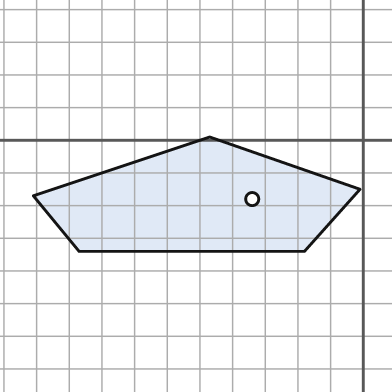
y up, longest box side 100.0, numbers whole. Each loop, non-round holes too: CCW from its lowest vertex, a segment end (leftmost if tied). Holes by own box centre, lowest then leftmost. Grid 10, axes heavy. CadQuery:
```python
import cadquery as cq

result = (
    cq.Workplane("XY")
    .moveTo(-87.0, -34.0)
    .lineTo(-18.0, -34.0)
    .lineTo(-1.0, -15.0)
    .lineTo(-47.0, 1.0)
    .lineTo(-101.0, -17.0)
    .close()
    .moveTo(-34.0, -18.0)
    .circle(2.0)
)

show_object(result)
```